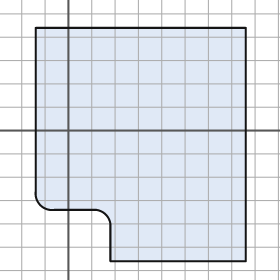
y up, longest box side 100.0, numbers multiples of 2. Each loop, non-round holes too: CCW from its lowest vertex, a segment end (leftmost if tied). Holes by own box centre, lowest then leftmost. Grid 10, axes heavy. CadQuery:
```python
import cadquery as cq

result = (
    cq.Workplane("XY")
    .moveTo(18.0, -56.0)
    .lineTo(76.0, -56.0)
    .lineTo(76.0, 44.0)
    .lineTo(-14.0, 44.0)
    .lineTo(-14.0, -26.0)
    .threePointArc((-12.0, -32.0), (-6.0, -34.0))
    .lineTo(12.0, -34.0)
    .threePointArc((16.0, -36.0), (18.0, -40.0))
    .close()
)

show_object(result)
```